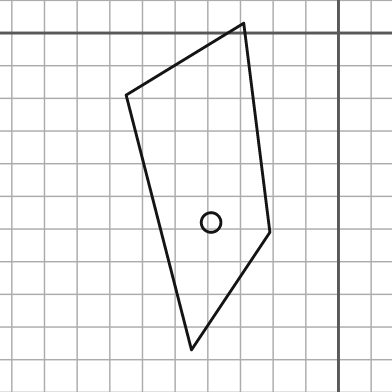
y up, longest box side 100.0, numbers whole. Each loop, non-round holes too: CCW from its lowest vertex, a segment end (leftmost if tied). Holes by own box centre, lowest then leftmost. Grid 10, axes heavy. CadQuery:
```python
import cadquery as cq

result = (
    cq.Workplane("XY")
    .moveTo(-45.0, -97.0)
    .lineTo(-21.0, -61.0)
    .lineTo(-29.0, 3.0)
    .lineTo(-65.0, -19.0)
    .close()
    .moveTo(-39.0, -58.0)
    .circle(3.0)
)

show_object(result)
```